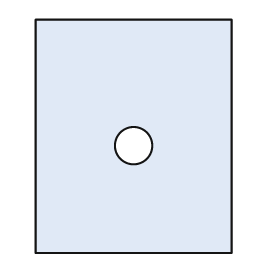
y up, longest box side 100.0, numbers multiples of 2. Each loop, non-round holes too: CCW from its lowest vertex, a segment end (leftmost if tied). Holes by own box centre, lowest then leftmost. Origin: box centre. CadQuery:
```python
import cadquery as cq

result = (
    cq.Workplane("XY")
    .moveTo(-42.0, -50.0)
    .lineTo(42.0, -50.0)
    .lineTo(42.0, 50.0)
    .lineTo(-42.0, 50.0)
    .close()
    .moveTo(0.0, -4.0)
    .circle(8.0)
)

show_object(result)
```